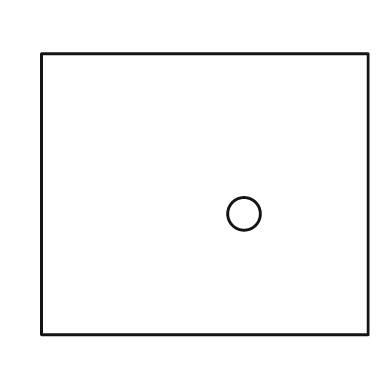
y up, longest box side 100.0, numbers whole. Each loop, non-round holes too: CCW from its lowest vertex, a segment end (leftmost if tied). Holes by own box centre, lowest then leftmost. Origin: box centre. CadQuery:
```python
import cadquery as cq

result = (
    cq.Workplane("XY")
    .moveTo(-50.0, -43.0)
    .lineTo(50.0, -43.0)
    .lineTo(50.0, 43.0)
    .lineTo(-50.0, 43.0)
    .close()
    .moveTo(12.0, -6.0)
    .circle(5.0)
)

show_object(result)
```